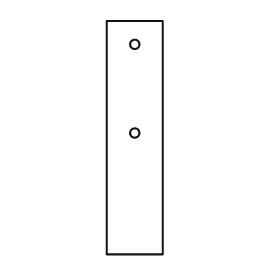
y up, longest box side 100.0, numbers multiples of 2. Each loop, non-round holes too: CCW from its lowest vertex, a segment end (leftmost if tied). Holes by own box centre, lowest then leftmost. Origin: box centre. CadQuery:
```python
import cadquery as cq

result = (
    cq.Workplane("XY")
    .moveTo(-12.0, -50.0)
    .lineTo(12.0, -50.0)
    .lineTo(12.0, 50.0)
    .lineTo(-12.0, 50.0)
    .close()
    .moveTo(0.0, 2.0)
    .circle(2.0)
    .moveTo(0.0, 40.0)
    .circle(2.0)
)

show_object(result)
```